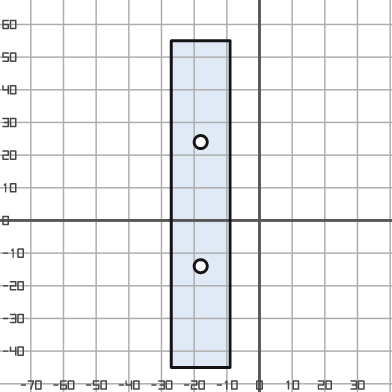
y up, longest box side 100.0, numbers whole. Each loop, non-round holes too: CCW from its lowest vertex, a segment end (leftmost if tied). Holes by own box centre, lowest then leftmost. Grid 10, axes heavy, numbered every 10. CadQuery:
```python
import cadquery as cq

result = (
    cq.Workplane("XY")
    .moveTo(-27.0, -45.0)
    .lineTo(-9.0, -45.0)
    .lineTo(-9.0, 55.0)
    .lineTo(-27.0, 55.0)
    .close()
    .moveTo(-18.0, -14.0)
    .circle(2.0)
    .moveTo(-18.0, 24.0)
    .circle(2.0)
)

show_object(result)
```